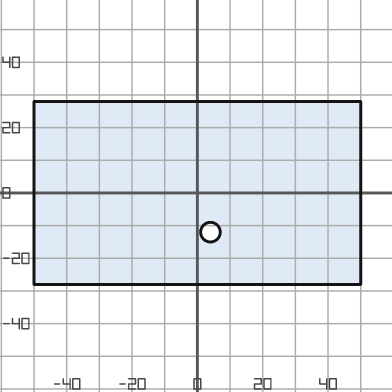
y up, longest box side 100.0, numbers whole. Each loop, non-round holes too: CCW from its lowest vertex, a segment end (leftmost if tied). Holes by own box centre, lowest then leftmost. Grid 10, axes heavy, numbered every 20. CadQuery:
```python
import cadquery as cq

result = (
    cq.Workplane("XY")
    .moveTo(-50.0, -28.0)
    .lineTo(50.0, -28.0)
    .lineTo(50.0, 28.0)
    .lineTo(-50.0, 28.0)
    .close()
    .moveTo(4.0, -12.0)
    .circle(3.0)
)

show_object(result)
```